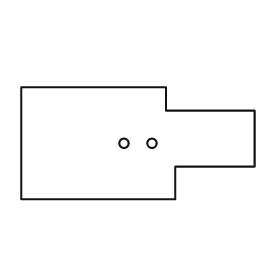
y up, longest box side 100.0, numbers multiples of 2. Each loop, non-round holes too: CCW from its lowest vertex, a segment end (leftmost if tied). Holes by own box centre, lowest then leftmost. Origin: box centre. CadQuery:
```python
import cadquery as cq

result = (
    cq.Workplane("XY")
    .moveTo(-50.0, -24.0)
    .lineTo(16.0, -24.0)
    .lineTo(16.0, -10.0)
    .lineTo(50.0, -10.0)
    .lineTo(50.0, 14.0)
    .lineTo(12.0, 14.0)
    .lineTo(12.0, 24.0)
    .lineTo(-50.0, 24.0)
    .close()
    .moveTo(-6.0, 0.0)
    .circle(2.0)
    .moveTo(6.0, 0.0)
    .circle(2.0)
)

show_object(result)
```